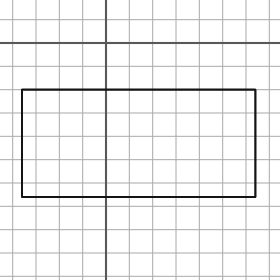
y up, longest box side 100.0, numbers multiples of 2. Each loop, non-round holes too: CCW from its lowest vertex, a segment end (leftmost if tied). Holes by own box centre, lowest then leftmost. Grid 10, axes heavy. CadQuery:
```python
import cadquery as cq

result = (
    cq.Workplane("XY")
    .moveTo(-36.0, -66.0)
    .lineTo(64.0, -66.0)
    .lineTo(64.0, -20.0)
    .lineTo(-36.0, -20.0)
    .close()
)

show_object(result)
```